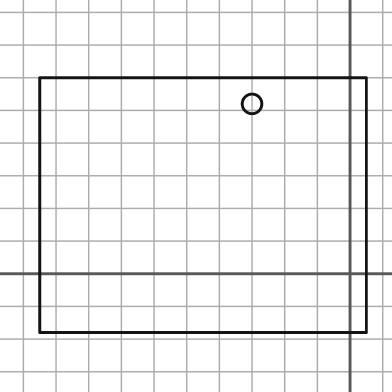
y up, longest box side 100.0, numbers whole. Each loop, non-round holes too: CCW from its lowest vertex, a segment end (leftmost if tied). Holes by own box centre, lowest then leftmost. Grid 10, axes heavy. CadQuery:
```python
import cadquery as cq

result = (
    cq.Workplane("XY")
    .moveTo(-95.0, -18.0)
    .lineTo(5.0, -18.0)
    .lineTo(5.0, 60.0)
    .lineTo(-95.0, 60.0)
    .close()
    .moveTo(-30.0, 52.0)
    .circle(3.0)
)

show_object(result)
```